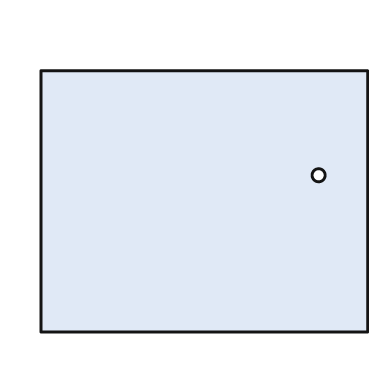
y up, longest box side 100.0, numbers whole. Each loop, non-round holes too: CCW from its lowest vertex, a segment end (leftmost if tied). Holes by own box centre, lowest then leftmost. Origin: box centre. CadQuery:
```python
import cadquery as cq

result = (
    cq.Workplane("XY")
    .moveTo(-50.0, -40.0)
    .lineTo(50.0, -40.0)
    .lineTo(50.0, 40.0)
    .lineTo(-50.0, 40.0)
    .close()
    .moveTo(35.0, 8.0)
    .circle(2.0)
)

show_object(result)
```